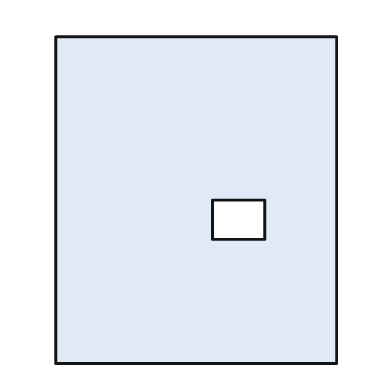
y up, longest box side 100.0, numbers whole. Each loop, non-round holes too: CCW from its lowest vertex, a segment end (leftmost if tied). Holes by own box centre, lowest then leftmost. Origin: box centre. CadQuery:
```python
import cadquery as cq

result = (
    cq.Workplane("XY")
    .moveTo(-43.0, -50.0)
    .lineTo(43.0, -50.0)
    .lineTo(43.0, 50.0)
    .lineTo(-43.0, 50.0)
    .close()
    .moveTo(5.0, -12.0)
    .lineTo(21.0, -12.0)
    .lineTo(21.0, 0.0)
    .lineTo(5.0, 0.0)
    .close()
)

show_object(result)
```